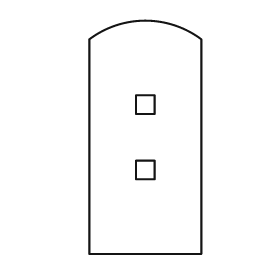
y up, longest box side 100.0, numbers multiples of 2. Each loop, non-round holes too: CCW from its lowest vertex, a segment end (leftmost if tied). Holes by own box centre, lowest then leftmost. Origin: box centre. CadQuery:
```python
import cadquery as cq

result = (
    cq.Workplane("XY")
    .moveTo(-24.0, -50.0)
    .lineTo(24.0, -50.0)
    .lineTo(24.0, 42.0)
    .threePointArc((0.0, 50.0), (-24.0, 42.0))
    .close()
    .moveTo(-4.0, -18.0)
    .lineTo(4.0, -18.0)
    .lineTo(4.0, -10.0)
    .lineTo(-4.0, -10.0)
    .close()
    .moveTo(-4.0, 10.0)
    .lineTo(4.0, 10.0)
    .lineTo(4.0, 18.0)
    .lineTo(-4.0, 18.0)
    .close()
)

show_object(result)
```